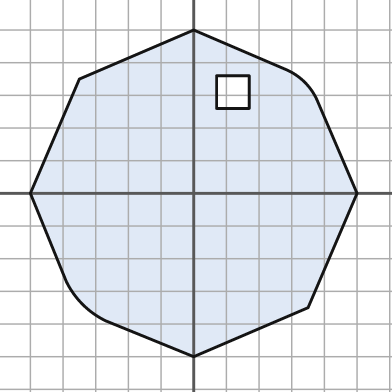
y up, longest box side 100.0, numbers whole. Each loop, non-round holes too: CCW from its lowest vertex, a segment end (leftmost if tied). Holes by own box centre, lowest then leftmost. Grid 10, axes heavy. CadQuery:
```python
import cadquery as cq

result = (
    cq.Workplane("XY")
    .moveTo(0.0, -50.0)
    .lineTo(35.0, -35.0)
    .lineTo(50.0, 0.0)
    .lineTo(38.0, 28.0)
    .threePointArc((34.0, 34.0), (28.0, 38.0))
    .lineTo(0.0, 50.0)
    .lineTo(-35.0, 35.0)
    .lineTo(-50.0, 0.0)
    .lineTo(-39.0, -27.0)
    .threePointArc((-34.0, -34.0), (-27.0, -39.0))
    .close()
    .moveTo(7.0, 26.0)
    .lineTo(17.0, 26.0)
    .lineTo(17.0, 36.0)
    .lineTo(7.0, 36.0)
    .close()
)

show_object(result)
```